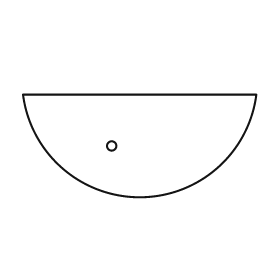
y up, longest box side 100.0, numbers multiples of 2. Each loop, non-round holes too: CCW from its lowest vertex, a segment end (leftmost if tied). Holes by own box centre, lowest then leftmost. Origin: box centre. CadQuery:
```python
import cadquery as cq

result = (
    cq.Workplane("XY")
    .moveTo(-50.0, 22.0)
    .threePointArc((0.0, -22.0), (50.0, 22.0))
    .close()
    .moveTo(-12.0, 0.0)
    .circle(2.0)
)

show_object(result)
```